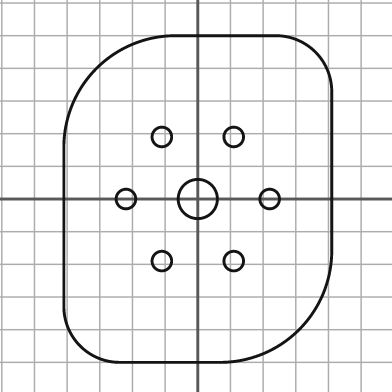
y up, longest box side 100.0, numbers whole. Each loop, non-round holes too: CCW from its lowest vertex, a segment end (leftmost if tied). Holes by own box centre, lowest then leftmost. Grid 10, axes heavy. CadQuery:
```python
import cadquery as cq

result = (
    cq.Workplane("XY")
    .moveTo(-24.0, -50.0)
    .lineTo(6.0, -50.0)
    .threePointArc((31.0, -40.0), (41.0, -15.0))
    .lineTo(41.0, 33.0)
    .threePointArc((36.0, 45.0), (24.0, 50.0))
    .lineTo(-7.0, 50.0)
    .threePointArc((-31.0, 40.0), (-41.0, 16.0))
    .lineTo(-41.0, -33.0)
    .threePointArc((-36.0, -45.0), (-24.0, -50.0))
    .close()
    .moveTo(-11.0, -19.0)
    .circle(3.0)
    .moveTo(11.0, -19.0)
    .circle(3.0)
    .moveTo(-22.0, 0.0)
    .circle(3.0)
    .moveTo(0.0, 0.0)
    .circle(6.0)
    .moveTo(22.0, 0.0)
    .circle(3.0)
    .moveTo(-11.0, 19.0)
    .circle(3.0)
    .moveTo(11.0, 19.0)
    .circle(3.0)
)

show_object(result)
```